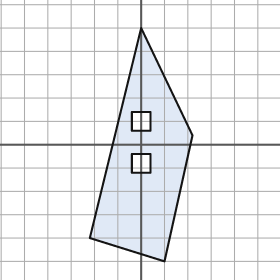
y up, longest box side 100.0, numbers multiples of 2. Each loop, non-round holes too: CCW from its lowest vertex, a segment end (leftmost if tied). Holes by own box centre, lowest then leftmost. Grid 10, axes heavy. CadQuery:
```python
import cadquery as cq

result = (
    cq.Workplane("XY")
    .moveTo(10.0, -50.0)
    .lineTo(22.0, 4.0)
    .lineTo(0.0, 50.0)
    .lineTo(-22.0, -40.0)
    .close()
    .moveTo(-4.0, -12.0)
    .lineTo(4.0, -12.0)
    .lineTo(4.0, -4.0)
    .lineTo(-4.0, -4.0)
    .close()
    .moveTo(-4.0, 6.0)
    .lineTo(4.0, 6.0)
    .lineTo(4.0, 14.0)
    .lineTo(-4.0, 14.0)
    .close()
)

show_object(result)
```